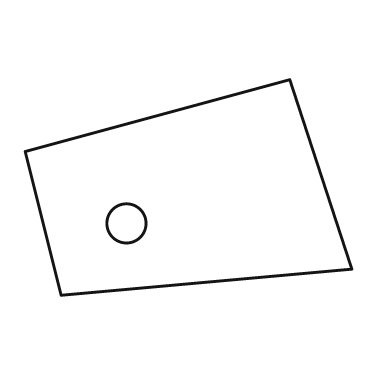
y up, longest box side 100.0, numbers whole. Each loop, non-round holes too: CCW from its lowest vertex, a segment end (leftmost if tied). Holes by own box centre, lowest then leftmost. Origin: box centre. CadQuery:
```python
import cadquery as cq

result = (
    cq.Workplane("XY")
    .moveTo(-39.0, -33.0)
    .lineTo(50.0, -25.0)
    .lineTo(31.0, 33.0)
    .lineTo(-50.0, 11.0)
    .close()
    .moveTo(-19.0, -11.0)
    .circle(6.0)
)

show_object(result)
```